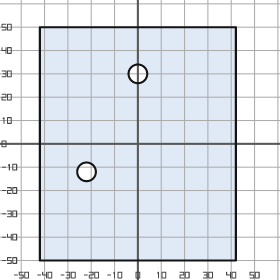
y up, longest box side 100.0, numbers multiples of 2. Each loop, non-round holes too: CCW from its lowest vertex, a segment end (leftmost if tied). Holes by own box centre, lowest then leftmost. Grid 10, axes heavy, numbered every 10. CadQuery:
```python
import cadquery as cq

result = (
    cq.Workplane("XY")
    .moveTo(-42.0, -50.0)
    .lineTo(42.0, -50.0)
    .lineTo(42.0, 50.0)
    .lineTo(-42.0, 50.0)
    .close()
    .moveTo(-22.0, -12.0)
    .circle(4.0)
    .moveTo(0.0, 30.0)
    .circle(4.0)
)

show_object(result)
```